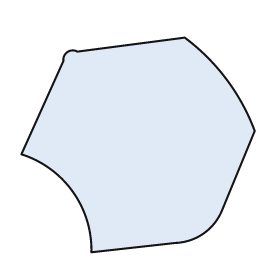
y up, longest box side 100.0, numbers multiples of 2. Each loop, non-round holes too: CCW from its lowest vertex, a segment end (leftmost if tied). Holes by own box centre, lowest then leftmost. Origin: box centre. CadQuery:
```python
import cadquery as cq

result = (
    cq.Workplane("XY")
    .moveTo(-20.0, -46.0)
    .lineTo(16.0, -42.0)
    .threePointArc((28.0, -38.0), (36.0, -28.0))
    .lineTo(50.0, 6.0)
    .threePointArc((38.0, 28.0), (20.0, 46.0))
    .lineTo(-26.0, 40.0)
    .threePointArc((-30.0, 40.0), (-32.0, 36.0))
    .lineTo(-50.0, -4.0)
    .threePointArc((-28.0, -20.0), (-20.0, -46.0))
    .close()
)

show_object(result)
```